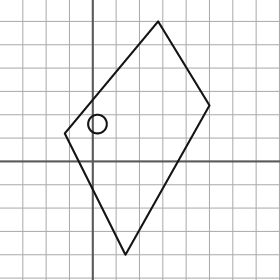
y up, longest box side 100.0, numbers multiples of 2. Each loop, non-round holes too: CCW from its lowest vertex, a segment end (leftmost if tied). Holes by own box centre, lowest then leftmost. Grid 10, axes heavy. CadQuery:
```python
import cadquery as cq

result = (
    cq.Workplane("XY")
    .moveTo(14.0, -40.0)
    .lineTo(50.0, 24.0)
    .lineTo(28.0, 60.0)
    .lineTo(-12.0, 12.0)
    .close()
    .moveTo(2.0, 16.0)
    .circle(4.0)
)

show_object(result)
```